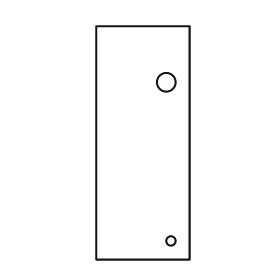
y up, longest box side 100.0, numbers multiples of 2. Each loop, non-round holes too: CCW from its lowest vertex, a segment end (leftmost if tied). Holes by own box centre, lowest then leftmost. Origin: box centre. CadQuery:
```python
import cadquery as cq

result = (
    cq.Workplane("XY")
    .moveTo(-20.0, -50.0)
    .lineTo(20.0, -50.0)
    .lineTo(20.0, 50.0)
    .lineTo(-20.0, 50.0)
    .close()
    .moveTo(12.0, -42.0)
    .circle(2.0)
    .moveTo(10.0, 26.0)
    .circle(4.0)
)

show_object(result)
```